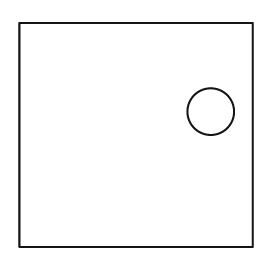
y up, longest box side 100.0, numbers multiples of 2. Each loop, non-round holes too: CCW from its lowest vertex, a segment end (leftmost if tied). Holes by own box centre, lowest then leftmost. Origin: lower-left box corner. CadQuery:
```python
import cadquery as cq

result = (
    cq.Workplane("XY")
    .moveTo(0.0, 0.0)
    .lineTo(100.0, 0.0)
    .lineTo(100.0, 96.0)
    .lineTo(0.0, 96.0)
    .close()
    .moveTo(82.0, 58.0)
    .circle(10.0)
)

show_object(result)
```